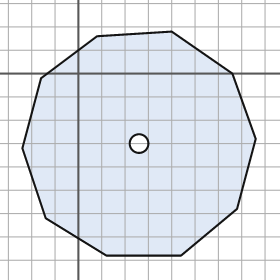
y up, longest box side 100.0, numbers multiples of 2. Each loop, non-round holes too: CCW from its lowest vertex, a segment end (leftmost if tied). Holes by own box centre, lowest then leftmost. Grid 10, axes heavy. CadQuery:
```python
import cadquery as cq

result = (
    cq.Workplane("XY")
    .moveTo(12.0, -78.0)
    .lineTo(44.0, -78.0)
    .lineTo(68.0, -58.0)
    .lineTo(76.0, -28.0)
    .lineTo(66.0, 0.0)
    .lineTo(40.0, 18.0)
    .lineTo(8.0, 16.0)
    .lineTo(-16.0, -2.0)
    .lineTo(-24.0, -32.0)
    .lineTo(-14.0, -62.0)
    .close()
    .moveTo(26.0, -30.0)
    .circle(4.0)
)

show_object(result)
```